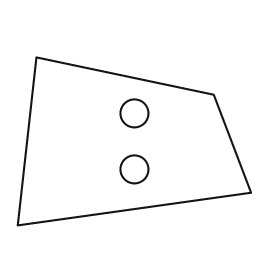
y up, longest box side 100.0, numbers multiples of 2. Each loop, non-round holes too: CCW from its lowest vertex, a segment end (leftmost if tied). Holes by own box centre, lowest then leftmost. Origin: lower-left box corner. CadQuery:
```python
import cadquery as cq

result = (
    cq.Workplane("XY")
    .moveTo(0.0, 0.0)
    .lineTo(100.0, 14.0)
    .lineTo(84.0, 56.0)
    .lineTo(8.0, 72.0)
    .close()
    .moveTo(50.0, 24.0)
    .circle(6.0)
    .moveTo(50.0, 48.0)
    .circle(6.0)
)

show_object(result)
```